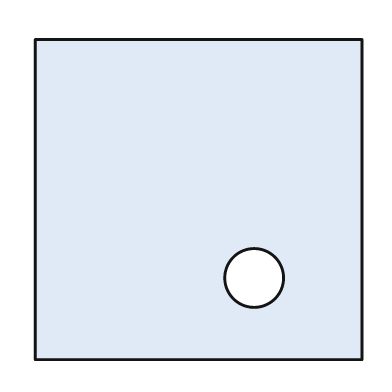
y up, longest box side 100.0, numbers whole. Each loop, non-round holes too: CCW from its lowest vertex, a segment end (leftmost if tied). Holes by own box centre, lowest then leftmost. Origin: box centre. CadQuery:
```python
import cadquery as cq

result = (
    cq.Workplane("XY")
    .moveTo(-50.0, -49.0)
    .lineTo(50.0, -49.0)
    .lineTo(50.0, 49.0)
    .lineTo(-50.0, 49.0)
    .close()
    .moveTo(17.0, -24.0)
    .circle(9.0)
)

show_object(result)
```